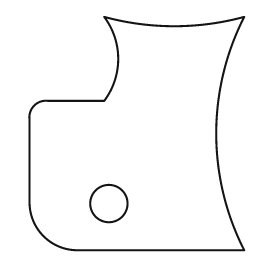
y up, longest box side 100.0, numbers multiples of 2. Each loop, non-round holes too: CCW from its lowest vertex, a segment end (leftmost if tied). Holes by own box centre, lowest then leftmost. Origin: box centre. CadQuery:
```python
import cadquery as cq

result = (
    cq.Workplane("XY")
    .moveTo(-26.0, -50.0)
    .lineTo(46.0, -50.0)
    .threePointArc((34.0, 0.0), (46.0, 50.0))
    .threePointArc((16.0, 46.0), (-14.0, 50.0))
    .threePointArc((-8.0, 32.0), (-14.0, 14.0))
    .lineTo(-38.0, 14.0)
    .threePointArc((-44.0, 12.0), (-46.0, 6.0))
    .lineTo(-46.0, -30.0)
    .threePointArc((-40.0, -44.0), (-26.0, -50.0))
    .close()
    .moveTo(-12.0, -30.0)
    .circle(8.0)
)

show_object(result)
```